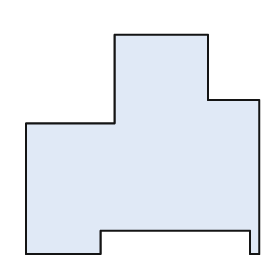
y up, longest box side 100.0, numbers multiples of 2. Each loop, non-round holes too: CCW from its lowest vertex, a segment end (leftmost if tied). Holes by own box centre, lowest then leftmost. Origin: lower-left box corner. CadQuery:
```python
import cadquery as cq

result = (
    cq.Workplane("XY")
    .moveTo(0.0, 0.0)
    .lineTo(32.0, 0.0)
    .lineTo(32.0, 10.0)
    .lineTo(96.0, 10.0)
    .lineTo(96.0, 0.0)
    .lineTo(100.0, 0.0)
    .lineTo(100.0, 66.0)
    .lineTo(78.0, 66.0)
    .lineTo(78.0, 94.0)
    .lineTo(38.0, 94.0)
    .lineTo(38.0, 56.0)
    .lineTo(0.0, 56.0)
    .close()
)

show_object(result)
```